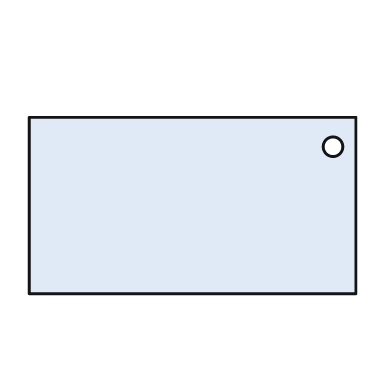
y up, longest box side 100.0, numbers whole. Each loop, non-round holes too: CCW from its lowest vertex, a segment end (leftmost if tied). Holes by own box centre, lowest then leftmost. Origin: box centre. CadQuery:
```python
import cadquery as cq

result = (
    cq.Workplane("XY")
    .moveTo(-50.0, -27.0)
    .lineTo(50.0, -27.0)
    .lineTo(50.0, 27.0)
    .lineTo(-50.0, 27.0)
    .close()
    .moveTo(43.0, 18.0)
    .circle(3.0)
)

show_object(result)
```